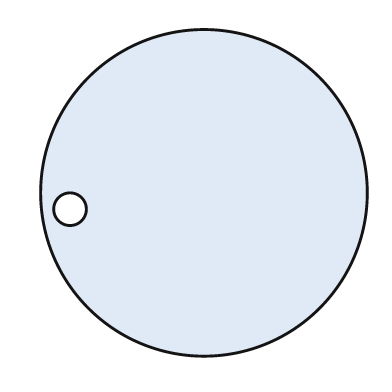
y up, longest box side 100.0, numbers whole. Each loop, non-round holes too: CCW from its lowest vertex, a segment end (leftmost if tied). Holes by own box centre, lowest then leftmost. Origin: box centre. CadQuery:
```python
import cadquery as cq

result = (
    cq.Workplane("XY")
    .moveTo(0.0, 0.0)
    .circle(50.0)
    .moveTo(-41.0, -5.0)
    .circle(5.0)
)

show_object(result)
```